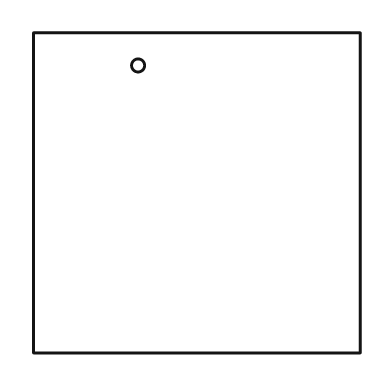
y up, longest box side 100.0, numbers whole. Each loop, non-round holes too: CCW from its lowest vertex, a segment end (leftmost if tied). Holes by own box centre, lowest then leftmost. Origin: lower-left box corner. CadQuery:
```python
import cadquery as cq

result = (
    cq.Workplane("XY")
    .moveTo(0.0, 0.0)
    .lineTo(100.0, 0.0)
    .lineTo(100.0, 98.0)
    .lineTo(0.0, 98.0)
    .close()
    .moveTo(32.0, 88.0)
    .circle(2.0)
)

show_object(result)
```